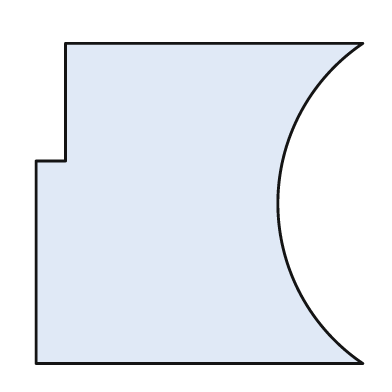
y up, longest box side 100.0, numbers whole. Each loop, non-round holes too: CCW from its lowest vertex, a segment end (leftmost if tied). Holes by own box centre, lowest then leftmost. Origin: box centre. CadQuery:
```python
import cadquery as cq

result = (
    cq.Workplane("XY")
    .moveTo(-50.0, -49.0)
    .lineTo(50.0, -49.0)
    .threePointArc((24.0, 0.0), (50.0, 49.0))
    .lineTo(-41.0, 49.0)
    .lineTo(-41.0, 13.0)
    .lineTo(-50.0, 13.0)
    .close()
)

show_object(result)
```